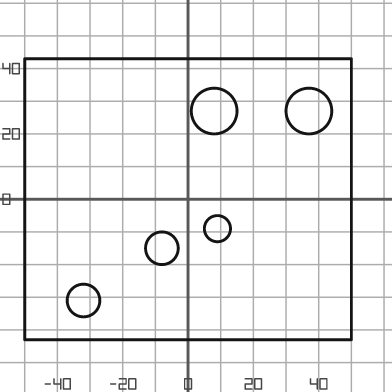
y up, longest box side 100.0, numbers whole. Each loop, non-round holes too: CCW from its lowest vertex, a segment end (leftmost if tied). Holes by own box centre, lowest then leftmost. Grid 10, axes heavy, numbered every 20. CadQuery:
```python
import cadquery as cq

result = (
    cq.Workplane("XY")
    .moveTo(-50.0, -43.0)
    .lineTo(50.0, -43.0)
    .lineTo(50.0, 43.0)
    .lineTo(-50.0, 43.0)
    .close()
    .moveTo(-32.0, -31.0)
    .circle(5.0)
    .moveTo(-8.0, -15.0)
    .circle(5.0)
    .moveTo(9.0, -9.0)
    .circle(4.0)
    .moveTo(8.0, 27.0)
    .circle(7.0)
    .moveTo(37.0, 27.0)
    .circle(7.0)
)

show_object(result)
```